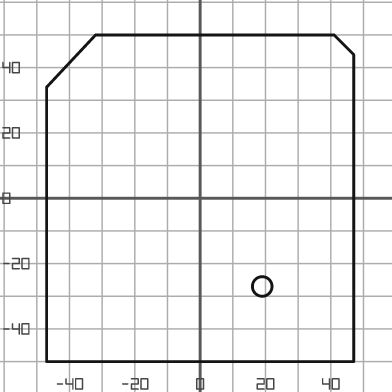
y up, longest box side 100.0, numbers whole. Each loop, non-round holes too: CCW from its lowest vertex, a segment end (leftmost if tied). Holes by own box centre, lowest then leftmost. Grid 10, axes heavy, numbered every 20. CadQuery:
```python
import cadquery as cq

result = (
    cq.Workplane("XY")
    .moveTo(-47.0, -50.0)
    .lineTo(47.0, -50.0)
    .lineTo(47.0, 44.0)
    .lineTo(41.0, 50.0)
    .lineTo(-32.0, 50.0)
    .lineTo(-47.0, 34.0)
    .close()
    .moveTo(19.0, -27.0)
    .circle(3.0)
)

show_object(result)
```